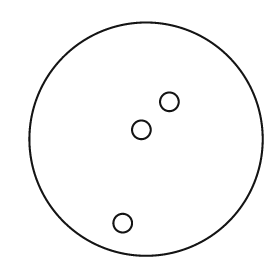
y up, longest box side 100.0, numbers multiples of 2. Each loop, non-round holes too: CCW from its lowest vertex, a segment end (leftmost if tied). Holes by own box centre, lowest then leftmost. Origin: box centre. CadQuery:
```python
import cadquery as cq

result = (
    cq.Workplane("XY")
    .moveTo(0.0, 0.0)
    .circle(50.0)
    .moveTo(-10.0, -36.0)
    .circle(4.0)
    .moveTo(-2.0, 4.0)
    .circle(4.0)
    .moveTo(10.0, 16.0)
    .circle(4.0)
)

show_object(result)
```